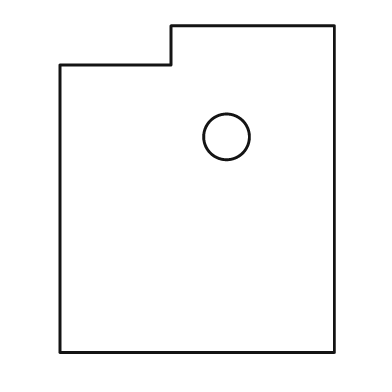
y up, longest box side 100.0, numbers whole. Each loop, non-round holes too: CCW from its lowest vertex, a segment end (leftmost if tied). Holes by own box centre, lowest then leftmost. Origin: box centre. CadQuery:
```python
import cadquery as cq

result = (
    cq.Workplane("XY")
    .moveTo(-42.0, -50.0)
    .lineTo(42.0, -50.0)
    .lineTo(42.0, 50.0)
    .lineTo(-8.0, 50.0)
    .lineTo(-8.0, 38.0)
    .lineTo(-42.0, 38.0)
    .close()
    .moveTo(9.0, 16.0)
    .circle(7.0)
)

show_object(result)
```